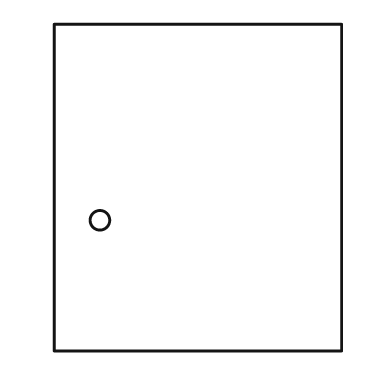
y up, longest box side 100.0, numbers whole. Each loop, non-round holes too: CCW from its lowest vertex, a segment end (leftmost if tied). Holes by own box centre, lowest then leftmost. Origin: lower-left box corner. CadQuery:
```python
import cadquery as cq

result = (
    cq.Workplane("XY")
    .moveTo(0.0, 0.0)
    .lineTo(88.0, 0.0)
    .lineTo(88.0, 100.0)
    .lineTo(0.0, 100.0)
    .close()
    .moveTo(14.0, 40.0)
    .circle(3.0)
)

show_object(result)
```